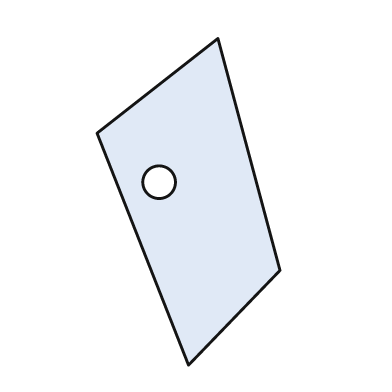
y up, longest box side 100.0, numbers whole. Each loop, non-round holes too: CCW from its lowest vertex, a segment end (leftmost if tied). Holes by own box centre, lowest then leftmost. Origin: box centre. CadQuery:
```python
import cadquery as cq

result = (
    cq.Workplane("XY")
    .moveTo(0.0, -50.0)
    .lineTo(28.0, -21.0)
    .lineTo(9.0, 50.0)
    .lineTo(-28.0, 21.0)
    .close()
    .moveTo(-9.0, 6.0)
    .circle(5.0)
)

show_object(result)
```